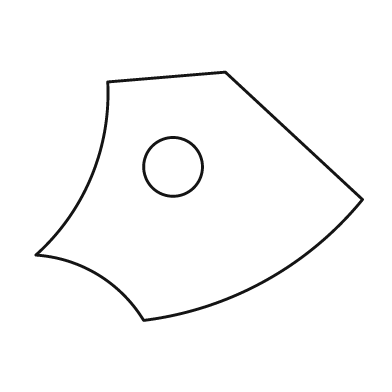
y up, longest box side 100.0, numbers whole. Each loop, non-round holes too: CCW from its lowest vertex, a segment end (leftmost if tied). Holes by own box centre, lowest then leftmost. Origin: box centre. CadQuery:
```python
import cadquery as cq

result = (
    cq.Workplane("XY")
    .moveTo(-17.0, -38.0)
    .threePointArc((20.0, -26.0), (50.0, -1.0))
    .lineTo(8.0, 38.0)
    .lineTo(-28.0, 35.0)
    .threePointArc((-33.0, 6.0), (-50.0, -18.0))
    .threePointArc((-31.0, -24.0), (-17.0, -38.0))
    .close()
    .moveTo(-8.0, 9.0)
    .circle(9.0)
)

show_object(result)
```